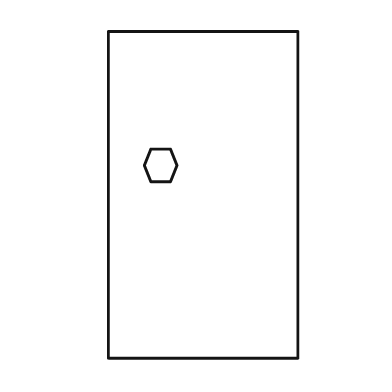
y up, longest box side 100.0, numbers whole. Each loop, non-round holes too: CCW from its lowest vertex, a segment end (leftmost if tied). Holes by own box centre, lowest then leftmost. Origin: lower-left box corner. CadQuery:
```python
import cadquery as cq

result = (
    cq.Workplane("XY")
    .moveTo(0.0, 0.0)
    .lineTo(58.0, 0.0)
    .lineTo(58.0, 100.0)
    .lineTo(0.0, 100.0)
    .close()
    .moveTo(13.0, 54.0)
    .lineTo(19.0, 54.0)
    .lineTo(21.0, 59.0)
    .lineTo(19.0, 64.0)
    .lineTo(13.0, 64.0)
    .lineTo(11.0, 59.0)
    .close()
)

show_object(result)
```